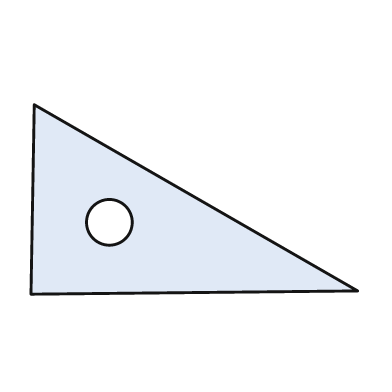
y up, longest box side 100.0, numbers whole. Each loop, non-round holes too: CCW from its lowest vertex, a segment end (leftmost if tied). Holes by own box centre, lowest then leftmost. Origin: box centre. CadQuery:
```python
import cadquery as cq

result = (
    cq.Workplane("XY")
    .moveTo(-50.0, -29.0)
    .lineTo(50.0, -28.0)
    .lineTo(-49.0, 29.0)
    .close()
    .moveTo(-26.0, -7.0)
    .circle(7.0)
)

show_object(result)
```